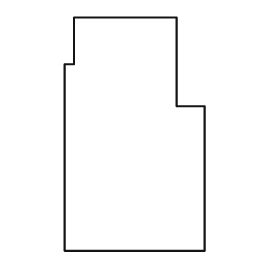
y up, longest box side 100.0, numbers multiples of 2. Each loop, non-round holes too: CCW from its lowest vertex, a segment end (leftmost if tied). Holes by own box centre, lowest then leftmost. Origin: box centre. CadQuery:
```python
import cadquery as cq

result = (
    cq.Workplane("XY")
    .moveTo(-30.0, -50.0)
    .lineTo(30.0, -50.0)
    .lineTo(30.0, 12.0)
    .lineTo(18.0, 12.0)
    .lineTo(18.0, 50.0)
    .lineTo(-26.0, 50.0)
    .lineTo(-26.0, 30.0)
    .lineTo(-30.0, 30.0)
    .close()
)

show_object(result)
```